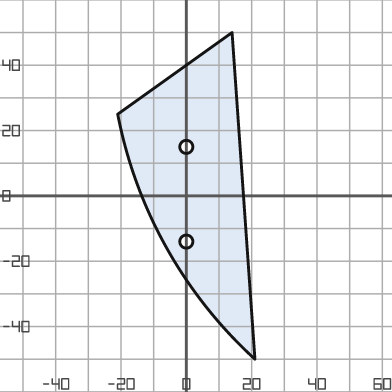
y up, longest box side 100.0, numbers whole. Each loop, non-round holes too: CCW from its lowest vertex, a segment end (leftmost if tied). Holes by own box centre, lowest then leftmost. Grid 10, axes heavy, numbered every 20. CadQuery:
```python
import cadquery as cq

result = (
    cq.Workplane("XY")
    .moveTo(21.0, -50.0)
    .lineTo(14.0, 50.0)
    .lineTo(-21.0, 25.0)
    .threePointArc((-6.0, -16.0), (21.0, -50.0))
    .close()
    .moveTo(0.0, -14.0)
    .circle(2.0)
    .moveTo(0.0, 15.0)
    .circle(2.0)
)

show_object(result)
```